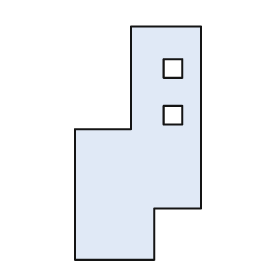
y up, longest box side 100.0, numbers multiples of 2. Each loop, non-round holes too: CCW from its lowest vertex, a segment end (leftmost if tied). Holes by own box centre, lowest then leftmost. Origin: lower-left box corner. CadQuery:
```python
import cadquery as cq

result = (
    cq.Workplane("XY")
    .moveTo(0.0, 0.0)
    .lineTo(34.0, 0.0)
    .lineTo(34.0, 22.0)
    .lineTo(54.0, 22.0)
    .lineTo(54.0, 100.0)
    .lineTo(24.0, 100.0)
    .lineTo(24.0, 56.0)
    .lineTo(0.0, 56.0)
    .close()
    .moveTo(38.0, 58.0)
    .lineTo(46.0, 58.0)
    .lineTo(46.0, 66.0)
    .lineTo(38.0, 66.0)
    .close()
    .moveTo(38.0, 78.0)
    .lineTo(46.0, 78.0)
    .lineTo(46.0, 86.0)
    .lineTo(38.0, 86.0)
    .close()
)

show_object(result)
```